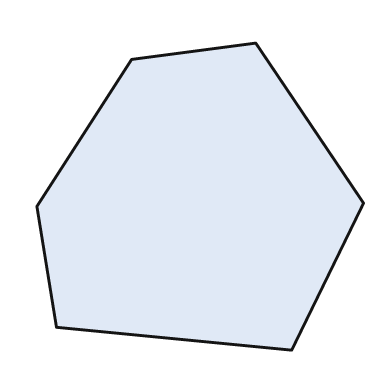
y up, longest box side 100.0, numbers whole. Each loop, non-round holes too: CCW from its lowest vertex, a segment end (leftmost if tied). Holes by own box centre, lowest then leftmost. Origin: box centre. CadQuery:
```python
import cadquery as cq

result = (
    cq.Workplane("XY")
    .moveTo(28.0, -47.0)
    .lineTo(50.0, -2.0)
    .lineTo(17.0, 47.0)
    .lineTo(-21.0, 42.0)
    .lineTo(-50.0, -3.0)
    .lineTo(-44.0, -40.0)
    .close()
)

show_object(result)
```